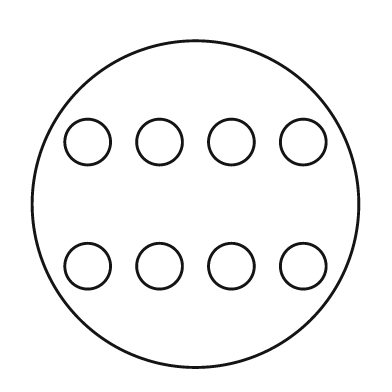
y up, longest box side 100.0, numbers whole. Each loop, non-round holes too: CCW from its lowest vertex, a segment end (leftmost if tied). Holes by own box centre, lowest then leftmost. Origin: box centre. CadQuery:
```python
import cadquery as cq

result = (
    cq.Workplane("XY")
    .moveTo(0.0, 0.0)
    .circle(50.0)
    .moveTo(-33.0, -19.0)
    .circle(7.0)
    .moveTo(-11.0, -19.0)
    .circle(7.0)
    .moveTo(11.0, -19.0)
    .circle(7.0)
    .moveTo(33.0, -19.0)
    .circle(7.0)
    .moveTo(-33.0, 19.0)
    .circle(7.0)
    .moveTo(-11.0, 19.0)
    .circle(7.0)
    .moveTo(11.0, 19.0)
    .circle(7.0)
    .moveTo(33.0, 19.0)
    .circle(7.0)
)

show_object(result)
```